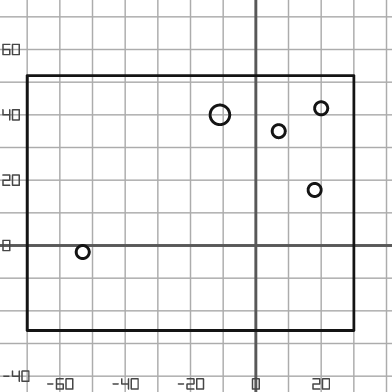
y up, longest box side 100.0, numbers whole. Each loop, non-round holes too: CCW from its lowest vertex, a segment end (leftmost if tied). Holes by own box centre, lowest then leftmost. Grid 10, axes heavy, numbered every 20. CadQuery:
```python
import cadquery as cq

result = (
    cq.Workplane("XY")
    .moveTo(-70.0, -26.0)
    .lineTo(30.0, -26.0)
    .lineTo(30.0, 52.0)
    .lineTo(-70.0, 52.0)
    .close()
    .moveTo(-53.0, -2.0)
    .circle(2.0)
    .moveTo(18.0, 17.0)
    .circle(2.0)
    .moveTo(7.0, 35.0)
    .circle(2.0)
    .moveTo(-11.0, 40.0)
    .circle(3.0)
    .moveTo(20.0, 42.0)
    .circle(2.0)
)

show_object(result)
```